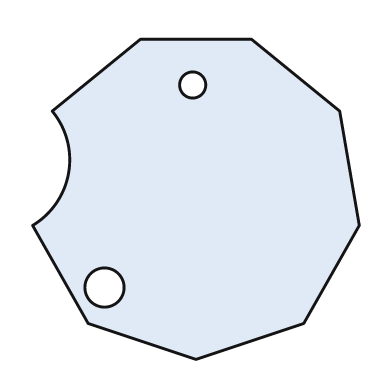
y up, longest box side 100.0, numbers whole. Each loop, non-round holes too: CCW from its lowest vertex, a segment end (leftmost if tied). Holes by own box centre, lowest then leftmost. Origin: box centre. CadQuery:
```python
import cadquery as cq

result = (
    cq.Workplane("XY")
    .moveTo(0.0, -49.0)
    .lineTo(33.0, -38.0)
    .lineTo(50.0, -8.0)
    .lineTo(44.0, 27.0)
    .lineTo(17.0, 49.0)
    .lineTo(-17.0, 49.0)
    .lineTo(-44.0, 27.0)
    .threePointArc((-39.0, 8.0), (-50.0, -8.0))
    .lineTo(-33.0, -38.0)
    .close()
    .moveTo(-28.0, -27.0)
    .circle(6.0)
    .moveTo(-1.0, 35.0)
    .circle(4.0)
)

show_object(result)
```